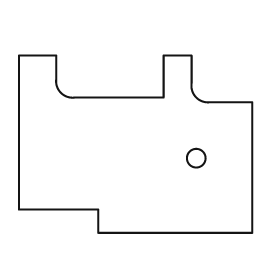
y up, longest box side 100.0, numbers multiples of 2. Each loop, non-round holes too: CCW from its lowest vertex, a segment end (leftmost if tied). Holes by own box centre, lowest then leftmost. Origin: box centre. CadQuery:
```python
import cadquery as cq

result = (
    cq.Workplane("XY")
    .moveTo(-16.0, -38.0)
    .lineTo(50.0, -38.0)
    .lineTo(50.0, 18.0)
    .lineTo(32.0, 18.0)
    .threePointArc((26.0, 20.0), (24.0, 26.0))
    .lineTo(24.0, 38.0)
    .lineTo(12.0, 38.0)
    .lineTo(12.0, 20.0)
    .lineTo(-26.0, 20.0)
    .threePointArc((-32.0, 22.0), (-34.0, 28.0))
    .lineTo(-34.0, 38.0)
    .lineTo(-50.0, 38.0)
    .lineTo(-50.0, -28.0)
    .lineTo(-16.0, -28.0)
    .close()
    .moveTo(26.0, -6.0)
    .circle(4.0)
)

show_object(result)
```